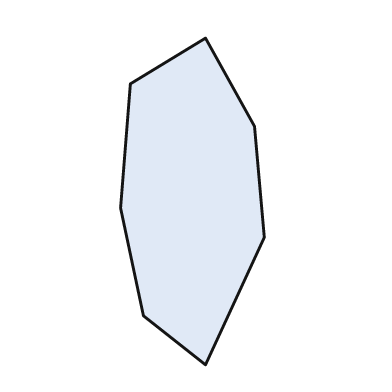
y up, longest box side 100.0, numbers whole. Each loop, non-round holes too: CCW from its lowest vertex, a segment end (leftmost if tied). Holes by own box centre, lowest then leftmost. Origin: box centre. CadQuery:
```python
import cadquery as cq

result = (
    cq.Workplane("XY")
    .moveTo(4.0, -50.0)
    .lineTo(22.0, -11.0)
    .lineTo(19.0, 23.0)
    .lineTo(4.0, 50.0)
    .lineTo(-19.0, 36.0)
    .lineTo(-22.0, -2.0)
    .lineTo(-15.0, -35.0)
    .close()
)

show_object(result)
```